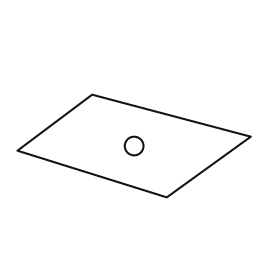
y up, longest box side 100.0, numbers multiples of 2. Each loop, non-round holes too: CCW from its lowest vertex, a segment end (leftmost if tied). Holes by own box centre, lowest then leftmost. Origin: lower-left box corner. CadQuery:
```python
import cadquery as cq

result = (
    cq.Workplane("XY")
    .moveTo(64.0, 0.0)
    .lineTo(100.0, 26.0)
    .lineTo(32.0, 44.0)
    .lineTo(0.0, 20.0)
    .close()
    .moveTo(50.0, 22.0)
    .circle(4.0)
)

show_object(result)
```